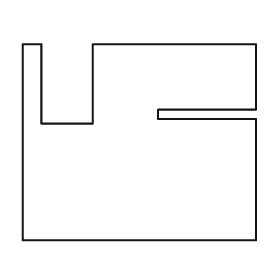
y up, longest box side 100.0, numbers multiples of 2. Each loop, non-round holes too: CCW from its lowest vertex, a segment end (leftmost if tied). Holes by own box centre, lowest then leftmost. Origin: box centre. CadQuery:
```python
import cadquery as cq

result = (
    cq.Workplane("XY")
    .moveTo(-50.0, -42.0)
    .lineTo(50.0, -42.0)
    .lineTo(50.0, 10.0)
    .lineTo(8.0, 10.0)
    .lineTo(8.0, 14.0)
    .lineTo(50.0, 14.0)
    .lineTo(50.0, 42.0)
    .lineTo(-20.0, 42.0)
    .lineTo(-20.0, 8.0)
    .lineTo(-42.0, 8.0)
    .lineTo(-42.0, 42.0)
    .lineTo(-50.0, 42.0)
    .close()
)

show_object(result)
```